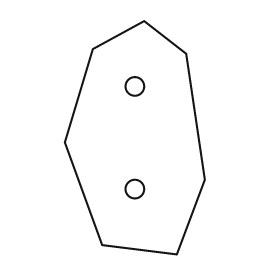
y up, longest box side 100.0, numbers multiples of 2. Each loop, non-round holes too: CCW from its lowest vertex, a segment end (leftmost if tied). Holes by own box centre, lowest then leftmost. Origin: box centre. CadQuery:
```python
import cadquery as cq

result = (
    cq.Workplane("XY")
    .moveTo(18.0, -50.0)
    .lineTo(30.0, -18.0)
    .lineTo(22.0, 36.0)
    .lineTo(4.0, 50.0)
    .lineTo(-18.0, 38.0)
    .lineTo(-30.0, -2.0)
    .lineTo(-14.0, -46.0)
    .close()
    .moveTo(0.0, -22.0)
    .circle(4.0)
    .moveTo(0.0, 22.0)
    .circle(4.0)
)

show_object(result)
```